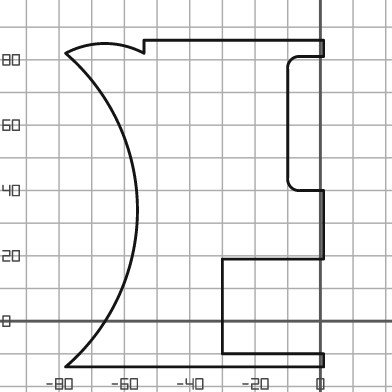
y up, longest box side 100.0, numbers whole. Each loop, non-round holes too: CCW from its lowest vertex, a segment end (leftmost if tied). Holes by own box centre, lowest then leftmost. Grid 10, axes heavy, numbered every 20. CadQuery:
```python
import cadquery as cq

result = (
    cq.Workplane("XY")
    .moveTo(-78.0, -14.0)
    .lineTo(1.0, -14.0)
    .lineTo(1.0, -10.0)
    .lineTo(-30.0, -10.0)
    .lineTo(-30.0, 19.0)
    .lineTo(1.0, 19.0)
    .lineTo(1.0, 40.0)
    .lineTo(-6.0, 40.0)
    .threePointArc((-9.0, 41.0), (-10.0, 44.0))
    .lineTo(-10.0, 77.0)
    .threePointArc((-9.0, 80.0), (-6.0, 81.0))
    .lineTo(1.0, 81.0)
    .lineTo(1.0, 86.0)
    .lineTo(-54.0, 86.0)
    .lineTo(-54.0, 82.0)
    .threePointArc((-66.0, 85.0), (-78.0, 82.0))
    .threePointArc((-56.0, 34.0), (-78.0, -14.0))
    .close()
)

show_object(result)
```